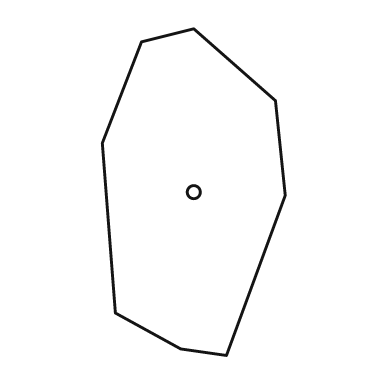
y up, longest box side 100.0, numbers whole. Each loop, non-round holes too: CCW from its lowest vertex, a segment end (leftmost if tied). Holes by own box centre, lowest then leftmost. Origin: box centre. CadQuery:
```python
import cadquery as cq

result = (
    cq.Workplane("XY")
    .moveTo(10.0, -50.0)
    .lineTo(28.0, -1.0)
    .lineTo(25.0, 28.0)
    .lineTo(0.0, 50.0)
    .lineTo(-16.0, 46.0)
    .lineTo(-28.0, 15.0)
    .lineTo(-24.0, -37.0)
    .lineTo(-4.0, -48.0)
    .close()
    .moveTo(0.0, 0.0)
    .circle(2.0)
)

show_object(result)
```